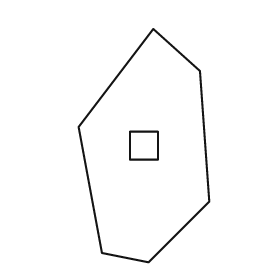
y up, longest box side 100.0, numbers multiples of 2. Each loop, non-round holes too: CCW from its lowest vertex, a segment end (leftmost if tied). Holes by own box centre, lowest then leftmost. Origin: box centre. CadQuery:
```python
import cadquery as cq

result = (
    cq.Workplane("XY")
    .moveTo(2.0, -50.0)
    .lineTo(28.0, -24.0)
    .lineTo(24.0, 32.0)
    .lineTo(4.0, 50.0)
    .lineTo(-28.0, 8.0)
    .lineTo(-18.0, -46.0)
    .close()
    .moveTo(-6.0, -6.0)
    .lineTo(6.0, -6.0)
    .lineTo(6.0, 6.0)
    .lineTo(-6.0, 6.0)
    .close()
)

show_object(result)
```